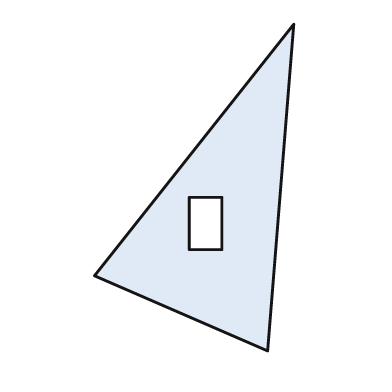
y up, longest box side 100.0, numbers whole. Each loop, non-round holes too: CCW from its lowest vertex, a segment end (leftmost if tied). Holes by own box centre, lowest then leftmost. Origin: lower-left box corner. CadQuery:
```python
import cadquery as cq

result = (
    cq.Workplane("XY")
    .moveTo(53.0, 0.0)
    .lineTo(61.0, 100.0)
    .lineTo(0.0, 23.0)
    .close()
    .moveTo(29.0, 31.0)
    .lineTo(39.0, 31.0)
    .lineTo(39.0, 47.0)
    .lineTo(29.0, 47.0)
    .close()
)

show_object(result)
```